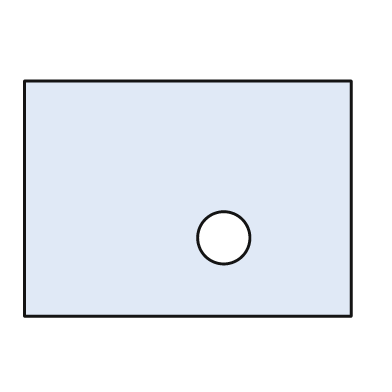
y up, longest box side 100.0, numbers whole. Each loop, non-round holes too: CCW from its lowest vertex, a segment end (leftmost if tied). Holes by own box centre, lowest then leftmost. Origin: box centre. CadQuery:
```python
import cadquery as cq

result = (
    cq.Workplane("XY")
    .moveTo(-50.0, -36.0)
    .lineTo(50.0, -36.0)
    .lineTo(50.0, 36.0)
    .lineTo(-50.0, 36.0)
    .close()
    .moveTo(11.0, -12.0)
    .circle(8.0)
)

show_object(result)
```